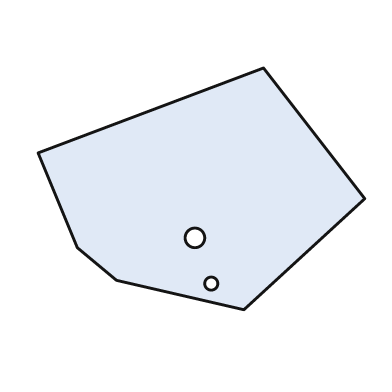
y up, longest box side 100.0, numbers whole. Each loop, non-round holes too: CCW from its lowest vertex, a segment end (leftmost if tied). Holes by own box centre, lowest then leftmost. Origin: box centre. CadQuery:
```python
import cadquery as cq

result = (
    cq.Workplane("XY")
    .moveTo(13.0, -37.0)
    .lineTo(50.0, -3.0)
    .lineTo(19.0, 37.0)
    .lineTo(-50.0, 11.0)
    .lineTo(-38.0, -18.0)
    .lineTo(-26.0, -28.0)
    .close()
    .moveTo(3.0, -29.0)
    .circle(2.0)
    .moveTo(-2.0, -15.0)
    .circle(3.0)
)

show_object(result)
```